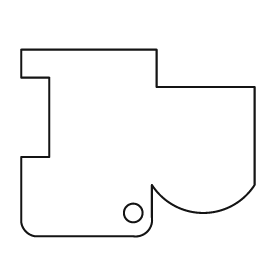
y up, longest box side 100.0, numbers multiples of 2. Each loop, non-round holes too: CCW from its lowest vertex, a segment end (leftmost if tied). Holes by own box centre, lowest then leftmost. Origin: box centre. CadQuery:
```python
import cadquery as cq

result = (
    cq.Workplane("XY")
    .moveTo(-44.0, -40.0)
    .lineTo(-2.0, -40.0)
    .threePointArc((4.0, -38.0), (6.0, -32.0))
    .lineTo(6.0, -18.0)
    .threePointArc((28.0, -30.0), (50.0, -18.0))
    .lineTo(50.0, 24.0)
    .lineTo(8.0, 24.0)
    .lineTo(8.0, 40.0)
    .lineTo(-50.0, 40.0)
    .lineTo(-50.0, 28.0)
    .lineTo(-38.0, 28.0)
    .lineTo(-38.0, -6.0)
    .lineTo(-50.0, -6.0)
    .lineTo(-50.0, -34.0)
    .threePointArc((-48.0, -38.0), (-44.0, -40.0))
    .close()
    .moveTo(-2.0, -30.0)
    .circle(4.0)
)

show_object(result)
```